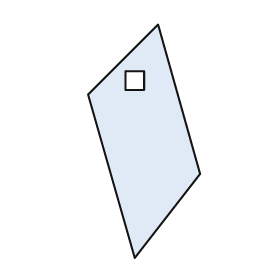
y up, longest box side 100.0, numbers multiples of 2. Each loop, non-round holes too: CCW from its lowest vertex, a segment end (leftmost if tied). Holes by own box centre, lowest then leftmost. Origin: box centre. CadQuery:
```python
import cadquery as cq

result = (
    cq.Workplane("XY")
    .moveTo(-4.0, -50.0)
    .lineTo(24.0, -14.0)
    .lineTo(6.0, 50.0)
    .lineTo(-24.0, 20.0)
    .close()
    .moveTo(-8.0, 22.0)
    .lineTo(0.0, 22.0)
    .lineTo(0.0, 30.0)
    .lineTo(-8.0, 30.0)
    .close()
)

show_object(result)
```